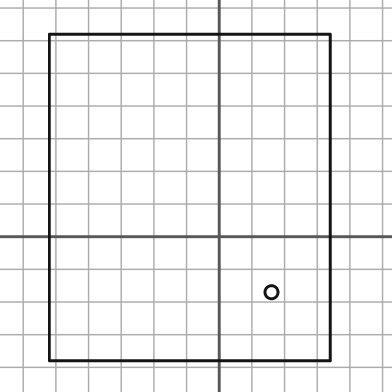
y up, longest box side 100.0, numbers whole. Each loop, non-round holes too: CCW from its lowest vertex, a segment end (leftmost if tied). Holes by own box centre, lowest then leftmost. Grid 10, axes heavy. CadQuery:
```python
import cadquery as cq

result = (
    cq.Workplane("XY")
    .moveTo(-52.0, -38.0)
    .lineTo(34.0, -38.0)
    .lineTo(34.0, 62.0)
    .lineTo(-52.0, 62.0)
    .close()
    .moveTo(16.0, -17.0)
    .circle(2.0)
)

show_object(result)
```